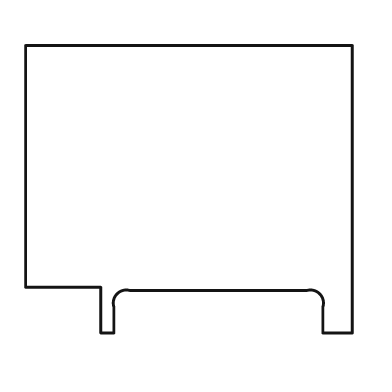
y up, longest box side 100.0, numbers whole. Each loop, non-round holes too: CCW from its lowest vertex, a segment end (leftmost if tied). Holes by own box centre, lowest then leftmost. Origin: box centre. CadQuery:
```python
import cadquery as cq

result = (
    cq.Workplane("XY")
    .moveTo(-27.0, -44.0)
    .lineTo(-23.0, -44.0)
    .lineTo(-23.0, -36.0)
    .threePointArc((-22.0, -32.0), (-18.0, -31.0))
    .lineTo(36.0, -31.0)
    .threePointArc((40.0, -32.0), (41.0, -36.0))
    .lineTo(41.0, -44.0)
    .lineTo(50.0, -44.0)
    .lineTo(50.0, 44.0)
    .lineTo(-50.0, 44.0)
    .lineTo(-50.0, -30.0)
    .lineTo(-27.0, -30.0)
    .close()
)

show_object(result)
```